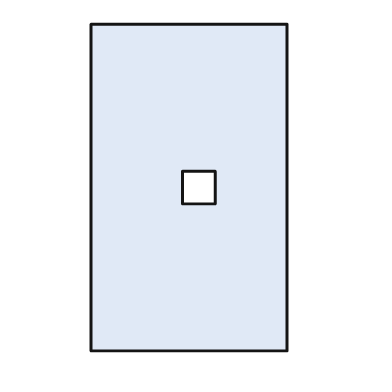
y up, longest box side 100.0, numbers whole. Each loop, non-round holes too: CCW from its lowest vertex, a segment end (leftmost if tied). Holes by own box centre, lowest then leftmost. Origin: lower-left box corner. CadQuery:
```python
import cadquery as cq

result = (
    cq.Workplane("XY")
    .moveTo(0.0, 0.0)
    .lineTo(60.0, 0.0)
    .lineTo(60.0, 100.0)
    .lineTo(0.0, 100.0)
    .close()
    .moveTo(28.0, 45.0)
    .lineTo(38.0, 45.0)
    .lineTo(38.0, 55.0)
    .lineTo(28.0, 55.0)
    .close()
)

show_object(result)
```